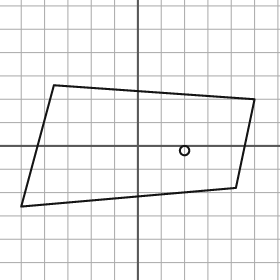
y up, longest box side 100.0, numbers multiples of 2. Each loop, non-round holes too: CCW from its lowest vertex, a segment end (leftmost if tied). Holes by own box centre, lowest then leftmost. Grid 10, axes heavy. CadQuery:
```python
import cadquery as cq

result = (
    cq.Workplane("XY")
    .moveTo(-50.0, -26.0)
    .lineTo(42.0, -18.0)
    .lineTo(50.0, 20.0)
    .lineTo(-36.0, 26.0)
    .close()
    .moveTo(20.0, -2.0)
    .circle(2.0)
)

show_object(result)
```